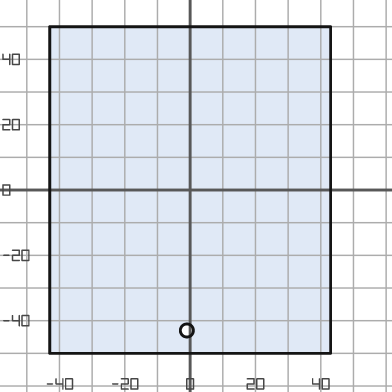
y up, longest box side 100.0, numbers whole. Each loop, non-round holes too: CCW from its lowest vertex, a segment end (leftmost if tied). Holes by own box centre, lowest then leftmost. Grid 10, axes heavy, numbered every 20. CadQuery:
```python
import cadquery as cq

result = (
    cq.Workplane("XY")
    .moveTo(-43.0, -50.0)
    .lineTo(43.0, -50.0)
    .lineTo(43.0, 50.0)
    .lineTo(-43.0, 50.0)
    .close()
    .moveTo(-1.0, -43.0)
    .circle(2.0)
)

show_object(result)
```